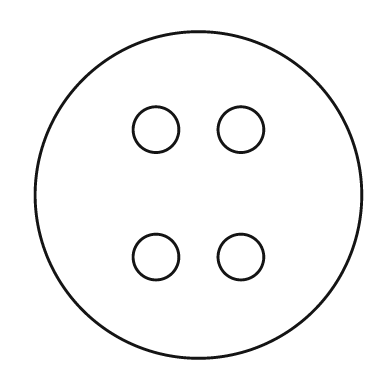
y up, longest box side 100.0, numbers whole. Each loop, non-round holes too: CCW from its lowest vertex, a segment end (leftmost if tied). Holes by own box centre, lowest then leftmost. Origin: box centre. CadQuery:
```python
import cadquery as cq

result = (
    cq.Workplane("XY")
    .moveTo(0.0, 0.0)
    .circle(50.0)
    .moveTo(-13.0, -19.0)
    .circle(7.0)
    .moveTo(13.0, -19.0)
    .circle(7.0)
    .moveTo(-13.0, 20.0)
    .circle(7.0)
    .moveTo(13.0, 20.0)
    .circle(7.0)
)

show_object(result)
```